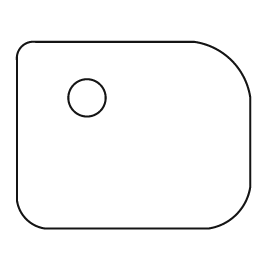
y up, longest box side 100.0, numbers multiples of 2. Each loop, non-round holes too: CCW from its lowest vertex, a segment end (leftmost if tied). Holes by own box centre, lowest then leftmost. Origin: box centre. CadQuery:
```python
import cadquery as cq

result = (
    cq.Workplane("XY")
    .moveTo(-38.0, -40.0)
    .lineTo(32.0, -40.0)
    .threePointArc((44.0, -34.0), (50.0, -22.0))
    .lineTo(50.0, 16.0)
    .threePointArc((42.0, 32.0), (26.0, 40.0))
    .lineTo(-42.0, 40.0)
    .threePointArc((-48.0, 38.0), (-50.0, 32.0))
    .lineTo(-50.0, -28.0)
    .threePointArc((-46.0, -36.0), (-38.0, -40.0))
    .close()
    .moveTo(-20.0, 16.0)
    .circle(8.0)
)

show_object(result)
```